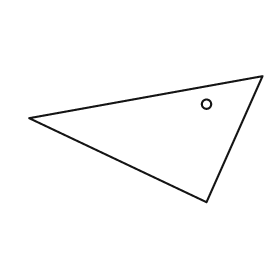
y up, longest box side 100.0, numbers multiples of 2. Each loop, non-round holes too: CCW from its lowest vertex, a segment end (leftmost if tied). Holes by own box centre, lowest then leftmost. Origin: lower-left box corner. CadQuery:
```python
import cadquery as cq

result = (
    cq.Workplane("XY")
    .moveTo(76.0, 0.0)
    .lineTo(100.0, 54.0)
    .lineTo(0.0, 36.0)
    .close()
    .moveTo(76.0, 42.0)
    .circle(2.0)
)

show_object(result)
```